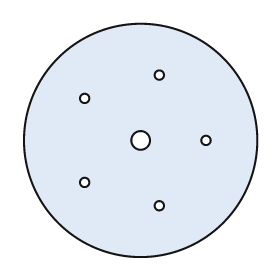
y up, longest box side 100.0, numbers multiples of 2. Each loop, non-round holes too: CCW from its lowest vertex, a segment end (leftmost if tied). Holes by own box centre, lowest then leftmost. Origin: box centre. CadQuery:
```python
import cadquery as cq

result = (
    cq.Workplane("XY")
    .moveTo(0.0, 0.0)
    .circle(50.0)
    .moveTo(8.0, -28.0)
    .circle(2.0)
    .moveTo(-24.0, -18.0)
    .circle(2.0)
    .moveTo(0.0, 0.0)
    .circle(4.0)
    .moveTo(28.0, 0.0)
    .circle(2.0)
    .moveTo(-24.0, 18.0)
    .circle(2.0)
    .moveTo(8.0, 28.0)
    .circle(2.0)
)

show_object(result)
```